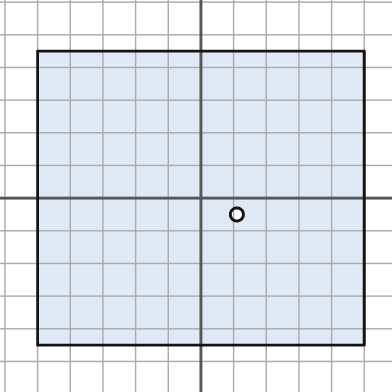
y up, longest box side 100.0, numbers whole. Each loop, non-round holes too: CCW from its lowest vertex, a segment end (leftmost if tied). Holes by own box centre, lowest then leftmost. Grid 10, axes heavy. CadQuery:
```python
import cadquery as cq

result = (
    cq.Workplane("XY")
    .moveTo(-50.0, -45.0)
    .lineTo(50.0, -45.0)
    .lineTo(50.0, 45.0)
    .lineTo(-50.0, 45.0)
    .close()
    .moveTo(11.0, -5.0)
    .circle(2.0)
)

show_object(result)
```